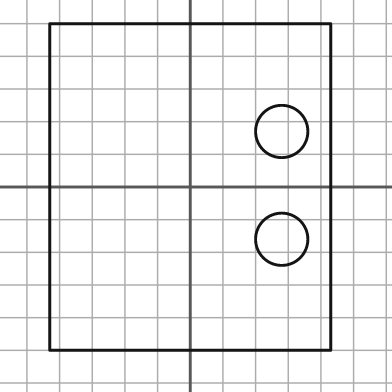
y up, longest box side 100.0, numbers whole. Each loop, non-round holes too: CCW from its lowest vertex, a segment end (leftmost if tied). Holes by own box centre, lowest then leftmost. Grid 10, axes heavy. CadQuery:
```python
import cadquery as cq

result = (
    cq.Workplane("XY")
    .moveTo(-43.0, -50.0)
    .lineTo(43.0, -50.0)
    .lineTo(43.0, 50.0)
    .lineTo(-43.0, 50.0)
    .close()
    .moveTo(28.0, -16.0)
    .circle(8.0)
    .moveTo(28.0, 17.0)
    .circle(8.0)
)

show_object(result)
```